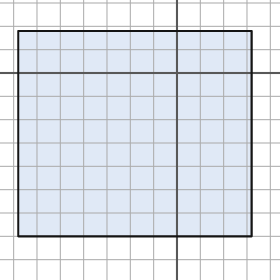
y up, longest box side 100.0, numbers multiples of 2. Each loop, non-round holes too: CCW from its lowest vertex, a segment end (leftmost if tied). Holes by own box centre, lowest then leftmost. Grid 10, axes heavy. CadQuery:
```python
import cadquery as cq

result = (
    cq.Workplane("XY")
    .moveTo(-68.0, -70.0)
    .lineTo(32.0, -70.0)
    .lineTo(32.0, 18.0)
    .lineTo(-68.0, 18.0)
    .close()
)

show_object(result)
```